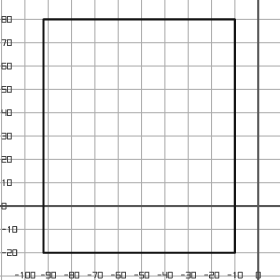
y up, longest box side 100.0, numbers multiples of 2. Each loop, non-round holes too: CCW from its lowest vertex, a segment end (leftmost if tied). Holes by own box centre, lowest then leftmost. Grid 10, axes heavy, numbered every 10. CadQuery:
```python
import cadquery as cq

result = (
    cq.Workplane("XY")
    .moveTo(-92.0, -20.0)
    .lineTo(-10.0, -20.0)
    .lineTo(-10.0, 80.0)
    .lineTo(-92.0, 80.0)
    .close()
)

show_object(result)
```